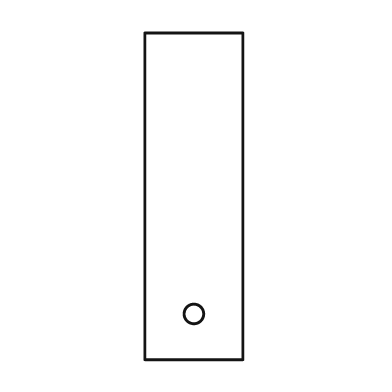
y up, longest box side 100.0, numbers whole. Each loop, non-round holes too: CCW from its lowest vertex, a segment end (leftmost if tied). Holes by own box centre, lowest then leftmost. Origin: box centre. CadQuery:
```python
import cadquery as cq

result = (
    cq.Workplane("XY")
    .moveTo(-15.0, -50.0)
    .lineTo(15.0, -50.0)
    .lineTo(15.0, 50.0)
    .lineTo(-15.0, 50.0)
    .close()
    .moveTo(0.0, -36.0)
    .circle(3.0)
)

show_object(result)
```